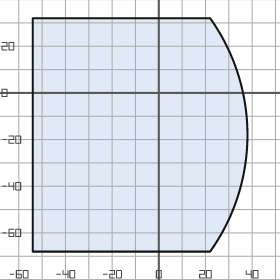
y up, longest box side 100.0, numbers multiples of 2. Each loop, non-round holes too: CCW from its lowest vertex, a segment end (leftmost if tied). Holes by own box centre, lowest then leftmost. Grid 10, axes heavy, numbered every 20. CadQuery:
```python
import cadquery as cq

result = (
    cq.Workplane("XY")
    .moveTo(-54.0, -68.0)
    .lineTo(22.0, -68.0)
    .threePointArc((38.0, -18.0), (22.0, 32.0))
    .lineTo(-54.0, 32.0)
    .close()
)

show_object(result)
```